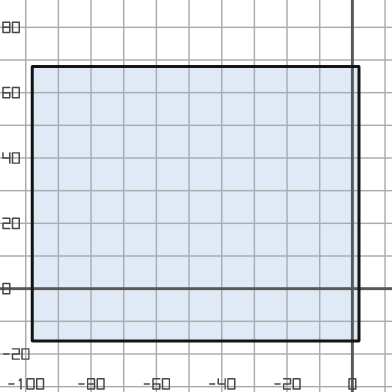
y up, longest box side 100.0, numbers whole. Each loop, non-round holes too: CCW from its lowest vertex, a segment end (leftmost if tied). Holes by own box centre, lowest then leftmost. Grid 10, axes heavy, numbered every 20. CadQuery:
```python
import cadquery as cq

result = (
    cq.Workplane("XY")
    .moveTo(-98.0, -16.0)
    .lineTo(2.0, -16.0)
    .lineTo(2.0, 68.0)
    .lineTo(-98.0, 68.0)
    .close()
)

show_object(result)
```